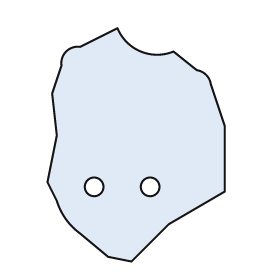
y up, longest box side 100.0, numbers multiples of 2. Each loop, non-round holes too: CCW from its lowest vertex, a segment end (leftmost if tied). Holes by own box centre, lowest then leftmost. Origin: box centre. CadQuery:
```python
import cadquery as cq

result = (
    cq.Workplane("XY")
    .moveTo(-2.0, -50.0)
    .lineTo(14.0, -34.0)
    .lineTo(38.0, -20.0)
    .lineTo(38.0, 8.0)
    .lineTo(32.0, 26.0)
    .threePointArc((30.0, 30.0), (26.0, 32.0))
    .lineTo(16.0, 40.0)
    .threePointArc((2.0, 40.0), (-8.0, 50.0))
    .lineTo(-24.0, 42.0)
    .threePointArc((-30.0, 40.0), (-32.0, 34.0))
    .lineTo(-36.0, 22.0)
    .lineTo(-34.0, 4.0)
    .lineTo(-38.0, -16.0)
    .lineTo(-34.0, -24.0)
    .threePointArc((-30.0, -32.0), (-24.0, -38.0))
    .lineTo(-12.0, -48.0)
    .close()
    .moveTo(-18.0, -18.0)
    .circle(4.0)
    .moveTo(6.0, -18.0)
    .circle(4.0)
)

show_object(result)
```